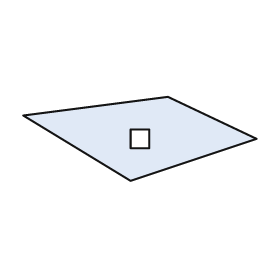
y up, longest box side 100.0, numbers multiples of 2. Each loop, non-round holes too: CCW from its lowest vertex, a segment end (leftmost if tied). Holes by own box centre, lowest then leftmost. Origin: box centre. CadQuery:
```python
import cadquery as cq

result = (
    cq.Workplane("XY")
    .moveTo(-4.0, -18.0)
    .lineTo(50.0, 0.0)
    .lineTo(12.0, 18.0)
    .lineTo(-50.0, 10.0)
    .close()
    .moveTo(-4.0, -4.0)
    .lineTo(4.0, -4.0)
    .lineTo(4.0, 4.0)
    .lineTo(-4.0, 4.0)
    .close()
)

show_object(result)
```